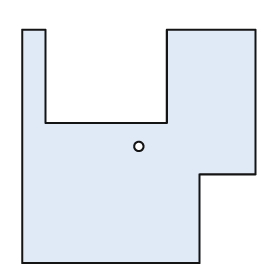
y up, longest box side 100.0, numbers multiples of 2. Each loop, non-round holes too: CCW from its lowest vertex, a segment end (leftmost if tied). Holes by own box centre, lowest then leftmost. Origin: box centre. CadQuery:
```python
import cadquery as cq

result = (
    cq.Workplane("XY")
    .moveTo(-50.0, -50.0)
    .lineTo(26.0, -50.0)
    .lineTo(26.0, -12.0)
    .lineTo(50.0, -12.0)
    .lineTo(50.0, 50.0)
    .lineTo(12.0, 50.0)
    .lineTo(12.0, 10.0)
    .lineTo(-40.0, 10.0)
    .lineTo(-40.0, 50.0)
    .lineTo(-50.0, 50.0)
    .close()
    .moveTo(0.0, 0.0)
    .circle(2.0)
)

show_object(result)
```